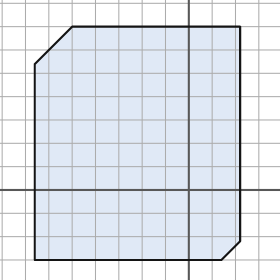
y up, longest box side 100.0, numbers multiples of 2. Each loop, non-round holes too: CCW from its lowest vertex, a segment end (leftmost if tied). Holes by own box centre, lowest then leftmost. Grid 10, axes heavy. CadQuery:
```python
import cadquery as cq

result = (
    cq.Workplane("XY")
    .moveTo(-66.0, -30.0)
    .lineTo(14.0, -30.0)
    .lineTo(22.0, -22.0)
    .lineTo(22.0, 70.0)
    .lineTo(-50.0, 70.0)
    .lineTo(-66.0, 54.0)
    .close()
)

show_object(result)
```